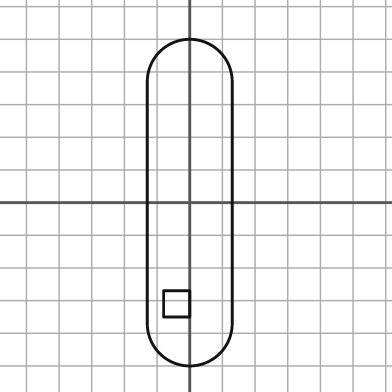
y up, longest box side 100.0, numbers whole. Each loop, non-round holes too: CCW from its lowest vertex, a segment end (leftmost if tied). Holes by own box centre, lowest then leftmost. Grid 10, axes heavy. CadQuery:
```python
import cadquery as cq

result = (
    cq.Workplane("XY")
    .moveTo(-13.0, -37.0)
    .threePointArc((0.0, -50.0), (13.0, -37.0))
    .lineTo(13.0, 37.0)
    .threePointArc((0.0, 50.0), (-13.0, 37.0))
    .close()
    .moveTo(-8.0, -35.0)
    .lineTo(0.0, -35.0)
    .lineTo(0.0, -27.0)
    .lineTo(-8.0, -27.0)
    .close()
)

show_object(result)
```